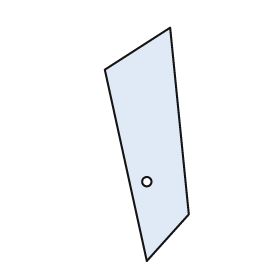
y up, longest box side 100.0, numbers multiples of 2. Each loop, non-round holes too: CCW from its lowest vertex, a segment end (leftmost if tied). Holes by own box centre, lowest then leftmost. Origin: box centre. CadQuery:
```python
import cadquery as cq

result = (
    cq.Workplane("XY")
    .moveTo(0.0, -50.0)
    .lineTo(18.0, -30.0)
    .lineTo(10.0, 50.0)
    .lineTo(-18.0, 32.0)
    .close()
    .moveTo(0.0, -16.0)
    .circle(2.0)
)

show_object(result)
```